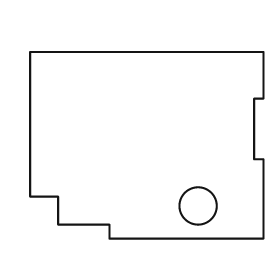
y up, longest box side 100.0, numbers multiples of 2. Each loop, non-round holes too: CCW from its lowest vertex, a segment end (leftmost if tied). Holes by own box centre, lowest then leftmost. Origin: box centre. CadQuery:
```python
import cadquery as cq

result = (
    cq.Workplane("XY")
    .moveTo(-16.0, -40.0)
    .lineTo(50.0, -40.0)
    .lineTo(50.0, -6.0)
    .lineTo(46.0, -6.0)
    .lineTo(46.0, 20.0)
    .lineTo(50.0, 20.0)
    .lineTo(50.0, 40.0)
    .lineTo(-50.0, 40.0)
    .lineTo(-50.0, -22.0)
    .lineTo(-38.0, -22.0)
    .lineTo(-38.0, -34.0)
    .lineTo(-16.0, -34.0)
    .close()
    .moveTo(22.0, -26.0)
    .circle(8.0)
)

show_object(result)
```